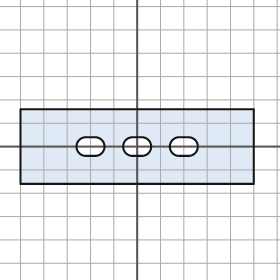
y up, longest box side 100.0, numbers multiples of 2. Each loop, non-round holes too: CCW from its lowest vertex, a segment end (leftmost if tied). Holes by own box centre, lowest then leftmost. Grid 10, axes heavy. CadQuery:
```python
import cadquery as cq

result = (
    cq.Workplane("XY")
    .moveTo(-50.0, -16.0)
    .lineTo(50.0, -16.0)
    .lineTo(50.0, 16.0)
    .lineTo(-50.0, 16.0)
    .close()
    .moveTo(-22.0, -4.0)
    .lineTo(-18.0, -4.0)
    .threePointArc((-14.0, 0.0), (-18.0, 4.0))
    .lineTo(-22.0, 4.0)
    .threePointArc((-26.0, 0.0), (-22.0, -4.0))
    .close()
    .moveTo(-2.0, -4.0)
    .lineTo(2.0, -4.0)
    .threePointArc((6.0, 0.0), (2.0, 4.0))
    .lineTo(-2.0, 4.0)
    .threePointArc((-6.0, 0.0), (-2.0, -4.0))
    .close()
    .moveTo(18.0, -4.0)
    .lineTo(22.0, -4.0)
    .threePointArc((26.0, 0.0), (22.0, 4.0))
    .lineTo(18.0, 4.0)
    .threePointArc((14.0, 0.0), (18.0, -4.0))
    .close()
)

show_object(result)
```